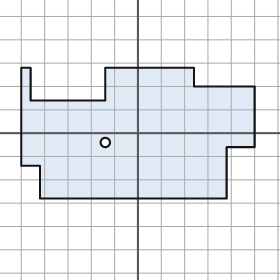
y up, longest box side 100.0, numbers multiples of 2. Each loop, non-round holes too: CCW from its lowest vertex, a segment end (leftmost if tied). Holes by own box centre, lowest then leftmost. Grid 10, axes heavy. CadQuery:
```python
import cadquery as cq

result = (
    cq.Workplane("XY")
    .moveTo(-42.0, -28.0)
    .lineTo(38.0, -28.0)
    .lineTo(38.0, -6.0)
    .lineTo(50.0, -6.0)
    .lineTo(50.0, 20.0)
    .lineTo(24.0, 20.0)
    .lineTo(24.0, 28.0)
    .lineTo(-14.0, 28.0)
    .lineTo(-14.0, 14.0)
    .lineTo(-46.0, 14.0)
    .lineTo(-46.0, 28.0)
    .lineTo(-50.0, 28.0)
    .lineTo(-50.0, -14.0)
    .lineTo(-42.0, -14.0)
    .close()
    .moveTo(-14.0, -4.0)
    .circle(2.0)
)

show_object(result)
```